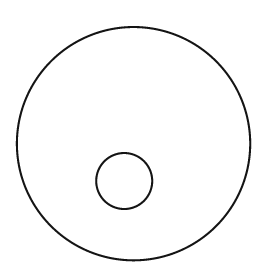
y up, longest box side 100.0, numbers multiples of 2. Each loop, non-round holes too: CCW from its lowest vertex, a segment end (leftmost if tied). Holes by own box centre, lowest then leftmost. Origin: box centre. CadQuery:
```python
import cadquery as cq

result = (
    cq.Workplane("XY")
    .moveTo(0.0, 0.0)
    .circle(50.0)
    .moveTo(-4.0, -16.0)
    .circle(12.0)
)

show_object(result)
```